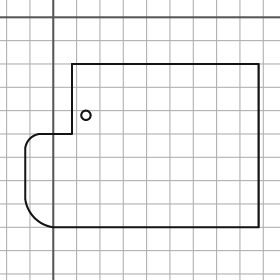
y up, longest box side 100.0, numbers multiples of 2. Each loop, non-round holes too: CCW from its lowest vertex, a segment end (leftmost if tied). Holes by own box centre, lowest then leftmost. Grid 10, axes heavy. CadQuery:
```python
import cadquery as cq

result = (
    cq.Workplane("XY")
    .moveTo(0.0, -90.0)
    .lineTo(88.0, -90.0)
    .lineTo(88.0, -20.0)
    .lineTo(8.0, -20.0)
    .lineTo(8.0, -50.0)
    .lineTo(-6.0, -50.0)
    .threePointArc((-10.0, -52.0), (-12.0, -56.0))
    .lineTo(-12.0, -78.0)
    .threePointArc((-8.0, -86.0), (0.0, -90.0))
    .close()
    .moveTo(14.0, -42.0)
    .circle(2.0)
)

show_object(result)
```